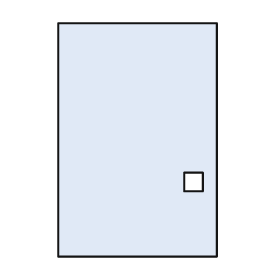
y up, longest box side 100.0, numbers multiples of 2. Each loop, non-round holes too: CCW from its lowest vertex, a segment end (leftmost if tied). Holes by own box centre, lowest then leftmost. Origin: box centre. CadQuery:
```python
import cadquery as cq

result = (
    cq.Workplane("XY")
    .moveTo(-34.0, -50.0)
    .lineTo(34.0, -50.0)
    .lineTo(34.0, 50.0)
    .lineTo(-34.0, 50.0)
    .close()
    .moveTo(20.0, -22.0)
    .lineTo(28.0, -22.0)
    .lineTo(28.0, -14.0)
    .lineTo(20.0, -14.0)
    .close()
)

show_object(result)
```